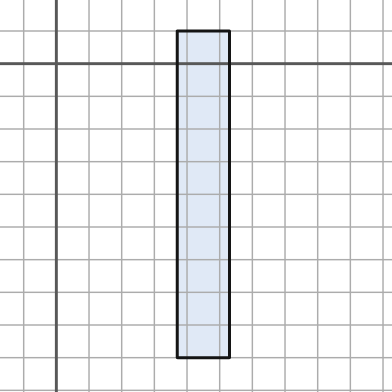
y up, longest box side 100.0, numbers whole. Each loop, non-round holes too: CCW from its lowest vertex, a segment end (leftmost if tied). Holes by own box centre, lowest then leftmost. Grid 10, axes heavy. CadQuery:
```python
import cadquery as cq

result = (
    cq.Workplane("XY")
    .moveTo(37.0, -90.0)
    .lineTo(53.0, -90.0)
    .lineTo(53.0, 10.0)
    .lineTo(37.0, 10.0)
    .close()
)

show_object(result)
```